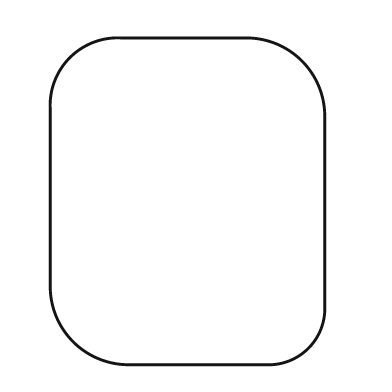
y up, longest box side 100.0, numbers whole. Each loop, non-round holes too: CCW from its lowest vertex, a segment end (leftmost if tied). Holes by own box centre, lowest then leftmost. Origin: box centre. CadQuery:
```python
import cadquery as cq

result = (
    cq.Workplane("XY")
    .moveTo(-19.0, -50.0)
    .lineTo(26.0, -50.0)
    .threePointArc((37.0, -45.0), (42.0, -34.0))
    .lineTo(42.0, 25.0)
    .threePointArc((35.0, 43.0), (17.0, 50.0))
    .lineTo(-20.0, 50.0)
    .threePointArc((-36.0, 44.0), (-42.0, 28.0))
    .lineTo(-42.0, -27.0)
    .threePointArc((-35.0, -43.0), (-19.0, -50.0))
    .close()
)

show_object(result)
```